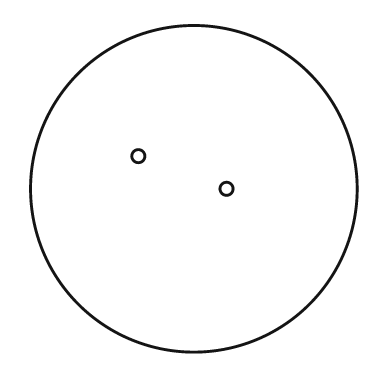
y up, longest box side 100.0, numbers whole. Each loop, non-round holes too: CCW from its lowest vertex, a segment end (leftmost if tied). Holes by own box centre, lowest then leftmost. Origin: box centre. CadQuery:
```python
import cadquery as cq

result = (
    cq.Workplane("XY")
    .moveTo(0.0, 0.0)
    .circle(50.0)
    .moveTo(10.0, 0.0)
    .circle(2.0)
    .moveTo(-17.0, 10.0)
    .circle(2.0)
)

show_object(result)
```